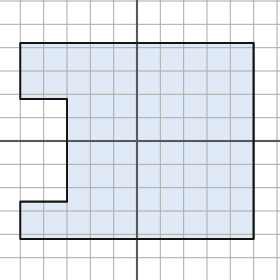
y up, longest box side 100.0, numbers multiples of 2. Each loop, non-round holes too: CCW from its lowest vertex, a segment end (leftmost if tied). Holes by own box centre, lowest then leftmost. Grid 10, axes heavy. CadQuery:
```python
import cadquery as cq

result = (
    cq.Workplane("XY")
    .moveTo(-50.0, -42.0)
    .lineTo(50.0, -42.0)
    .lineTo(50.0, 42.0)
    .lineTo(-50.0, 42.0)
    .lineTo(-50.0, 18.0)
    .lineTo(-30.0, 18.0)
    .lineTo(-30.0, -26.0)
    .lineTo(-50.0, -26.0)
    .close()
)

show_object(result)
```